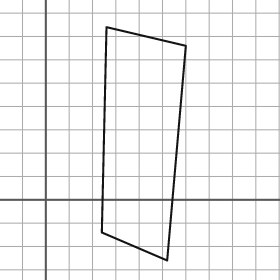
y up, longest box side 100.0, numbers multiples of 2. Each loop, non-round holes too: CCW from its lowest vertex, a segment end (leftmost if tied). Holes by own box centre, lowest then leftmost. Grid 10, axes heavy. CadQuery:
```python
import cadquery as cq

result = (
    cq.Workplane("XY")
    .moveTo(52.0, -26.0)
    .lineTo(60.0, 66.0)
    .lineTo(26.0, 74.0)
    .lineTo(24.0, -14.0)
    .close()
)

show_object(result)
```